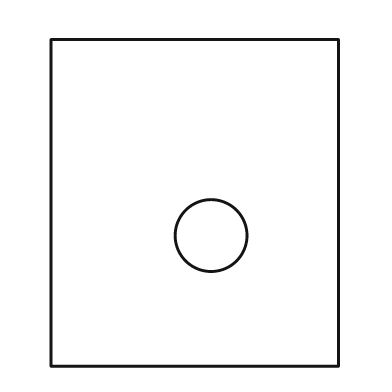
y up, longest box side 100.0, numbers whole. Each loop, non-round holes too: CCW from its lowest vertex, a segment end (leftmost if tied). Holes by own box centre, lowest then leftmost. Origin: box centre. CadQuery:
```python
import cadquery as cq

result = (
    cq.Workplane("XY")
    .moveTo(-44.0, -50.0)
    .lineTo(44.0, -50.0)
    .lineTo(44.0, 50.0)
    .lineTo(-44.0, 50.0)
    .close()
    .moveTo(5.0, -10.0)
    .circle(11.0)
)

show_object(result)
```